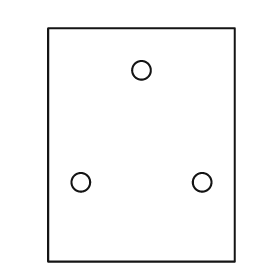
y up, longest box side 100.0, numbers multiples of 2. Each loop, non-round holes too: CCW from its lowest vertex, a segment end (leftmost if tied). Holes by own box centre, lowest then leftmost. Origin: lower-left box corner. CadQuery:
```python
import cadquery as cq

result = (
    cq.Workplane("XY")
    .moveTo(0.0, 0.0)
    .lineTo(80.0, 0.0)
    .lineTo(80.0, 100.0)
    .lineTo(0.0, 100.0)
    .close()
    .moveTo(14.0, 34.0)
    .circle(4.0)
    .moveTo(66.0, 34.0)
    .circle(4.0)
    .moveTo(40.0, 82.0)
    .circle(4.0)
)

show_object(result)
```